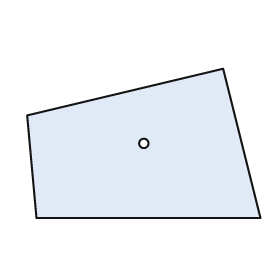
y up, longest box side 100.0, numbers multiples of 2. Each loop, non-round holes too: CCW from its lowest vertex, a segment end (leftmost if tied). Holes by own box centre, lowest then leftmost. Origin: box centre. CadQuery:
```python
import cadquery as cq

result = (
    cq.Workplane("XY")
    .moveTo(-46.0, -32.0)
    .lineTo(50.0, -32.0)
    .lineTo(34.0, 32.0)
    .lineTo(-50.0, 12.0)
    .close()
    .moveTo(0.0, 0.0)
    .circle(2.0)
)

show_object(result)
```